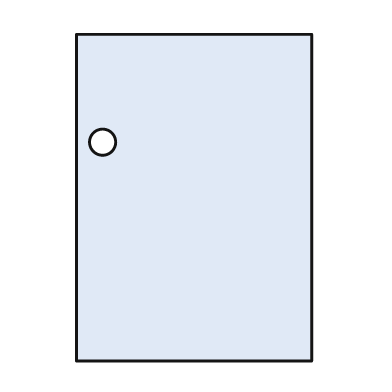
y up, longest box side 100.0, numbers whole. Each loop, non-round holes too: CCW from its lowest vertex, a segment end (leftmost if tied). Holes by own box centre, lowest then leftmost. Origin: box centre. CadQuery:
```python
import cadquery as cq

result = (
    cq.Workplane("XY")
    .moveTo(-36.0, -50.0)
    .lineTo(36.0, -50.0)
    .lineTo(36.0, 50.0)
    .lineTo(-36.0, 50.0)
    .close()
    .moveTo(-28.0, 17.0)
    .circle(4.0)
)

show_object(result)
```